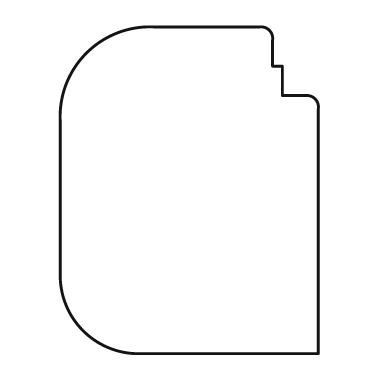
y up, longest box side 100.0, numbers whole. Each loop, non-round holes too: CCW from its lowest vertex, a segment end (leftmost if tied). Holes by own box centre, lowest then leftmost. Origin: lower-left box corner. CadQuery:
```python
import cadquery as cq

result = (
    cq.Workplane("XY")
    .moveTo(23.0, 0.0)
    .lineTo(79.0, 0.0)
    .lineTo(79.0, 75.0)
    .threePointArc((78.0, 78.0), (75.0, 79.0))
    .lineTo(68.0, 79.0)
    .lineTo(68.0, 88.0)
    .lineTo(65.0, 88.0)
    .lineTo(65.0, 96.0)
    .threePointArc((64.0, 99.0), (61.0, 100.0))
    .lineTo(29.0, 100.0)
    .threePointArc((8.0, 92.0), (0.0, 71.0))
    .lineTo(0.0, 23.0)
    .threePointArc((7.0, 7.0), (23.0, 0.0))
    .close()
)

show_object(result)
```